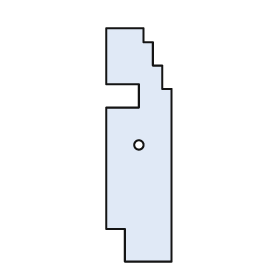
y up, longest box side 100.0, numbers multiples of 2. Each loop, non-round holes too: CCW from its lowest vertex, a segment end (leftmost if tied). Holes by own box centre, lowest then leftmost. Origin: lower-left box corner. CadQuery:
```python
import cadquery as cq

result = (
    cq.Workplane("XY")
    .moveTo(8.0, 0.0)
    .lineTo(28.0, 0.0)
    .lineTo(28.0, 74.0)
    .lineTo(24.0, 74.0)
    .lineTo(24.0, 84.0)
    .lineTo(20.0, 84.0)
    .lineTo(20.0, 94.0)
    .lineTo(16.0, 94.0)
    .lineTo(16.0, 100.0)
    .lineTo(0.0, 100.0)
    .lineTo(0.0, 76.0)
    .lineTo(14.0, 76.0)
    .lineTo(14.0, 66.0)
    .lineTo(0.0, 66.0)
    .lineTo(0.0, 14.0)
    .lineTo(8.0, 14.0)
    .close()
    .moveTo(14.0, 50.0)
    .circle(2.0)
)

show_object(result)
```